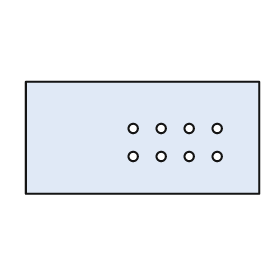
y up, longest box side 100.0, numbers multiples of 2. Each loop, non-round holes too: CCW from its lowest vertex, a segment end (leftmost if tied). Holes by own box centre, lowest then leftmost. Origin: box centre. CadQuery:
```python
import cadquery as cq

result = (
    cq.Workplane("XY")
    .moveTo(-50.0, -24.0)
    .lineTo(50.0, -24.0)
    .lineTo(50.0, 24.0)
    .lineTo(-50.0, 24.0)
    .close()
    .moveTo(-4.0, -8.0)
    .circle(2.0)
    .moveTo(8.0, -8.0)
    .circle(2.0)
    .moveTo(20.0, -8.0)
    .circle(2.0)
    .moveTo(32.0, -8.0)
    .circle(2.0)
    .moveTo(-4.0, 4.0)
    .circle(2.0)
    .moveTo(8.0, 4.0)
    .circle(2.0)
    .moveTo(20.0, 4.0)
    .circle(2.0)
    .moveTo(32.0, 4.0)
    .circle(2.0)
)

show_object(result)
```